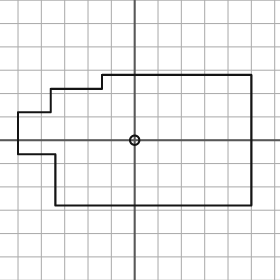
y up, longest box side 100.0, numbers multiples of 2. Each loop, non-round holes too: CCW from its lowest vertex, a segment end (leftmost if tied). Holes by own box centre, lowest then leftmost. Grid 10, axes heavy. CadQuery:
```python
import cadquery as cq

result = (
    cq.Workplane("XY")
    .moveTo(-34.0, -28.0)
    .lineTo(50.0, -28.0)
    .lineTo(50.0, 28.0)
    .lineTo(-14.0, 28.0)
    .lineTo(-14.0, 22.0)
    .lineTo(-36.0, 22.0)
    .lineTo(-36.0, 12.0)
    .lineTo(-50.0, 12.0)
    .lineTo(-50.0, -6.0)
    .lineTo(-34.0, -6.0)
    .close()
    .moveTo(0.0, 0.0)
    .circle(2.0)
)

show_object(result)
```